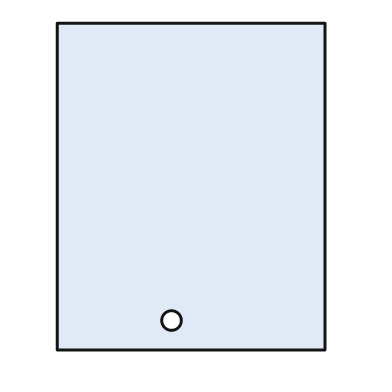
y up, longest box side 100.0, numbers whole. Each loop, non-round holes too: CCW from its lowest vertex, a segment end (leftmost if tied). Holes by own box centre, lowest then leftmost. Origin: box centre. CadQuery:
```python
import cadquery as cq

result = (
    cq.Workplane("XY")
    .moveTo(-41.0, -50.0)
    .lineTo(41.0, -50.0)
    .lineTo(41.0, 50.0)
    .lineTo(-41.0, 50.0)
    .close()
    .moveTo(-6.0, -41.0)
    .circle(3.0)
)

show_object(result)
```